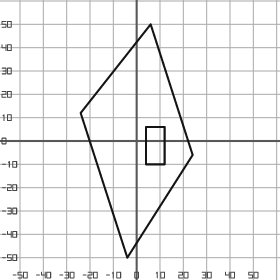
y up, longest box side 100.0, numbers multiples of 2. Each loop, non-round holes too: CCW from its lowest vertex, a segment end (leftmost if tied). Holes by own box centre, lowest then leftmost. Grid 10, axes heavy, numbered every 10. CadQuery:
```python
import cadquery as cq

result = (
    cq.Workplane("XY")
    .moveTo(-4.0, -50.0)
    .lineTo(24.0, -6.0)
    .lineTo(6.0, 50.0)
    .lineTo(-24.0, 12.0)
    .close()
    .moveTo(4.0, -10.0)
    .lineTo(12.0, -10.0)
    .lineTo(12.0, 6.0)
    .lineTo(4.0, 6.0)
    .close()
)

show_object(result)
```